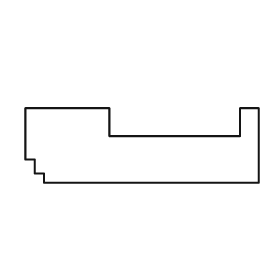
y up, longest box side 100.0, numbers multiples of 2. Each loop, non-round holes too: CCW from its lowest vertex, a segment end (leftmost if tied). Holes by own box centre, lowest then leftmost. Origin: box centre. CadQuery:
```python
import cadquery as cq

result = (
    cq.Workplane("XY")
    .moveTo(-42.0, -16.0)
    .lineTo(50.0, -16.0)
    .lineTo(50.0, 16.0)
    .lineTo(42.0, 16.0)
    .lineTo(42.0, 4.0)
    .lineTo(-14.0, 4.0)
    .lineTo(-14.0, 16.0)
    .lineTo(-50.0, 16.0)
    .lineTo(-50.0, -6.0)
    .lineTo(-46.0, -6.0)
    .lineTo(-46.0, -12.0)
    .lineTo(-42.0, -12.0)
    .close()
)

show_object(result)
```